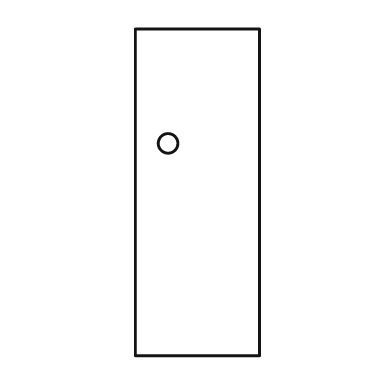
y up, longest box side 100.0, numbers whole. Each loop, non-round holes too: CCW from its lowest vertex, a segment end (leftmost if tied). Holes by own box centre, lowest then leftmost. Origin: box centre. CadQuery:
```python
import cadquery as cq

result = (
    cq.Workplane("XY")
    .moveTo(-19.0, -50.0)
    .lineTo(19.0, -50.0)
    .lineTo(19.0, 50.0)
    .lineTo(-19.0, 50.0)
    .close()
    .moveTo(-9.0, 15.0)
    .circle(3.0)
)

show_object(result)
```